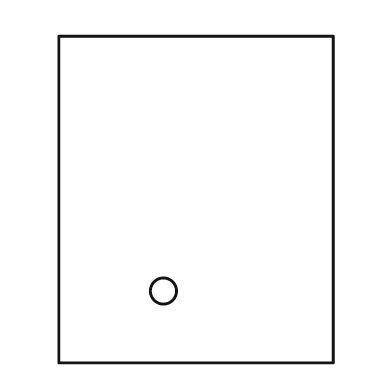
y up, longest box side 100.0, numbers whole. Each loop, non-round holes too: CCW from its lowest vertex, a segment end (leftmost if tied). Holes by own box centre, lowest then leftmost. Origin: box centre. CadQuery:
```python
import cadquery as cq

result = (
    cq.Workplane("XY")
    .moveTo(-42.0, -50.0)
    .lineTo(42.0, -50.0)
    .lineTo(42.0, 50.0)
    .lineTo(-42.0, 50.0)
    .close()
    .moveTo(-10.0, -28.0)
    .circle(4.0)
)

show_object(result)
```